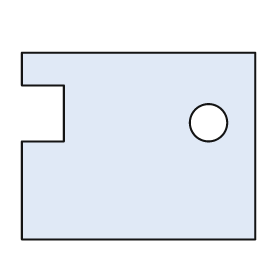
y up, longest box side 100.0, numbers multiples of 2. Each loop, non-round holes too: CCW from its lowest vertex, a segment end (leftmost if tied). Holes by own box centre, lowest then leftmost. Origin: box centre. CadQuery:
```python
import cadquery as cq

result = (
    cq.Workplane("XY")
    .moveTo(-50.0, -40.0)
    .lineTo(50.0, -40.0)
    .lineTo(50.0, 40.0)
    .lineTo(-50.0, 40.0)
    .lineTo(-50.0, 26.0)
    .lineTo(-32.0, 26.0)
    .lineTo(-32.0, 2.0)
    .lineTo(-50.0, 2.0)
    .close()
    .moveTo(30.0, 10.0)
    .circle(8.0)
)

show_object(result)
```